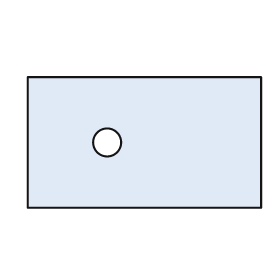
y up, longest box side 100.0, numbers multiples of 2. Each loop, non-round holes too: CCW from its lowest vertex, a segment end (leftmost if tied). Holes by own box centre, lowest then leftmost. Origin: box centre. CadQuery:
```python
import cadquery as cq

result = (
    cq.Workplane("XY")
    .moveTo(-50.0, -28.0)
    .lineTo(50.0, -28.0)
    .lineTo(50.0, 28.0)
    .lineTo(-50.0, 28.0)
    .close()
    .moveTo(-16.0, 0.0)
    .circle(6.0)
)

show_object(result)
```